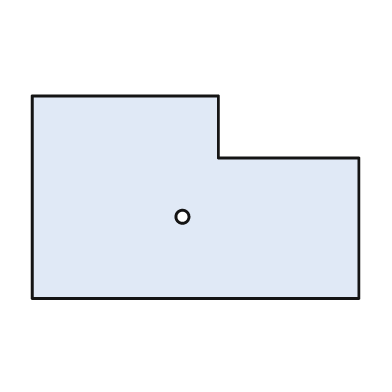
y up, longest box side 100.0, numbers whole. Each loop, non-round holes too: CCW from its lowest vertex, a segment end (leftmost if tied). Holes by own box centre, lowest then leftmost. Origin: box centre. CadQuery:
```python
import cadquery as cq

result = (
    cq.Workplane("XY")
    .moveTo(-50.0, -31.0)
    .lineTo(50.0, -31.0)
    .lineTo(50.0, 12.0)
    .lineTo(7.0, 12.0)
    .lineTo(7.0, 31.0)
    .lineTo(-50.0, 31.0)
    .close()
    .moveTo(-4.0, -6.0)
    .circle(2.0)
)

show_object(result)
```